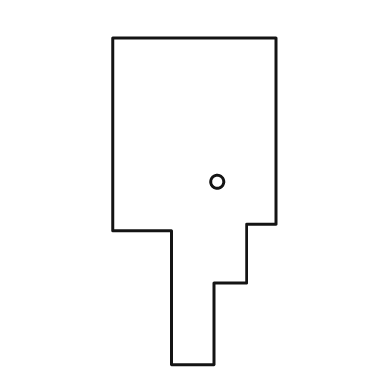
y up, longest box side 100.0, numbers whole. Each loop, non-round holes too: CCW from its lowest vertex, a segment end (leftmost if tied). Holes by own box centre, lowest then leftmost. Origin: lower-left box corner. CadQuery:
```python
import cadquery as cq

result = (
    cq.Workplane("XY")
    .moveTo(18.0, 0.0)
    .lineTo(31.0, 0.0)
    .lineTo(31.0, 25.0)
    .lineTo(41.0, 25.0)
    .lineTo(41.0, 43.0)
    .lineTo(50.0, 43.0)
    .lineTo(50.0, 100.0)
    .lineTo(0.0, 100.0)
    .lineTo(0.0, 41.0)
    .lineTo(18.0, 41.0)
    .close()
    .moveTo(32.0, 56.0)
    .circle(2.0)
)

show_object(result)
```